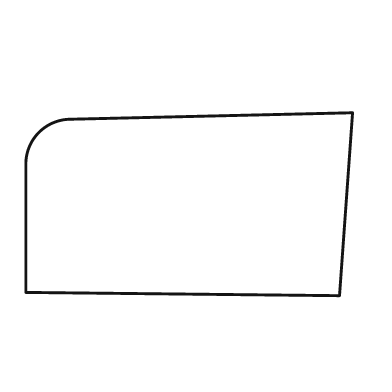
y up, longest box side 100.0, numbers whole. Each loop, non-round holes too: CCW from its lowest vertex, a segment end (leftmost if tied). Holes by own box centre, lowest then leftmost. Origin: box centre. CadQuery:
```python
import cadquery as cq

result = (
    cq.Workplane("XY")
    .moveTo(46.0, -28.0)
    .lineTo(50.0, 28.0)
    .lineTo(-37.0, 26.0)
    .threePointArc((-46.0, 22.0), (-50.0, 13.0))
    .lineTo(-50.0, -27.0)
    .close()
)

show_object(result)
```